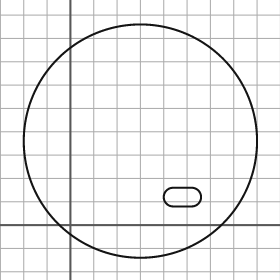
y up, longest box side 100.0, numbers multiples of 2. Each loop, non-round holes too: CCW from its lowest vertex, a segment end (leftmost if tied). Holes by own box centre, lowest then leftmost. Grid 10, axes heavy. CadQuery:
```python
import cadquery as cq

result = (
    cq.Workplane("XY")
    .moveTo(30.0, 36.0)
    .circle(50.0)
    .moveTo(44.0, 8.0)
    .lineTo(52.0, 8.0)
    .threePointArc((56.0, 12.0), (52.0, 16.0))
    .lineTo(44.0, 16.0)
    .threePointArc((40.0, 12.0), (44.0, 8.0))
    .close()
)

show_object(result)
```